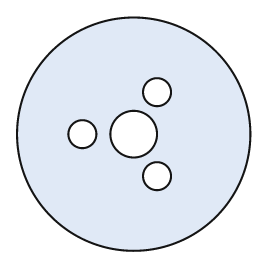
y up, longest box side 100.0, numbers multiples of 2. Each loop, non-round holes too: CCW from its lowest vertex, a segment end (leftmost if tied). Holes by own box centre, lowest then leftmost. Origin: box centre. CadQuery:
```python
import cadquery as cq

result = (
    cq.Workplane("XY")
    .moveTo(0.0, 0.0)
    .circle(50.0)
    .moveTo(10.0, -18.0)
    .circle(6.0)
    .moveTo(-22.0, 0.0)
    .circle(6.0)
    .moveTo(0.0, 0.0)
    .circle(10.0)
    .moveTo(10.0, 18.0)
    .circle(6.0)
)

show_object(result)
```